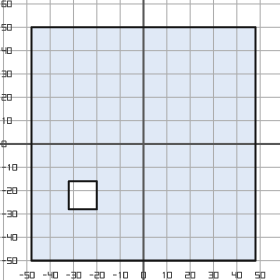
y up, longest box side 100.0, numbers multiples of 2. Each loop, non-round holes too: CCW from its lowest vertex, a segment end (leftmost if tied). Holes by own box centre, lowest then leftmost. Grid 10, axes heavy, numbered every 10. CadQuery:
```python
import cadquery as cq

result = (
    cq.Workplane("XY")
    .moveTo(-48.0, -50.0)
    .lineTo(48.0, -50.0)
    .lineTo(48.0, 50.0)
    .lineTo(-48.0, 50.0)
    .close()
    .moveTo(-32.0, -28.0)
    .lineTo(-20.0, -28.0)
    .lineTo(-20.0, -16.0)
    .lineTo(-32.0, -16.0)
    .close()
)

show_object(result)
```